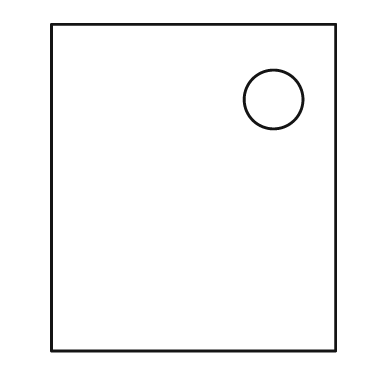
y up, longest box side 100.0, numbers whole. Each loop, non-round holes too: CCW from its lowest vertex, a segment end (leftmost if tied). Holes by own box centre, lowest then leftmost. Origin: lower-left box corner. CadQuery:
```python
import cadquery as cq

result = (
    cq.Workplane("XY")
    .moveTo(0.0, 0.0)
    .lineTo(87.0, 0.0)
    .lineTo(87.0, 100.0)
    .lineTo(0.0, 100.0)
    .close()
    .moveTo(68.0, 77.0)
    .circle(9.0)
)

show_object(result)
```